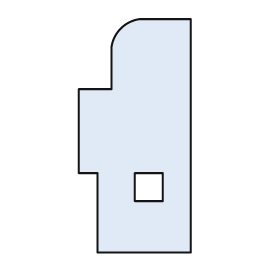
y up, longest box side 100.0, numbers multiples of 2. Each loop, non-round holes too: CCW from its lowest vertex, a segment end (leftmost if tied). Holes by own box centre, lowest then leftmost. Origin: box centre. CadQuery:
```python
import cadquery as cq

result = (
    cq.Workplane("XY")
    .moveTo(-16.0, -50.0)
    .lineTo(24.0, -50.0)
    .lineTo(24.0, 50.0)
    .lineTo(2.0, 50.0)
    .threePointArc((-6.0, 46.0), (-10.0, 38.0))
    .lineTo(-10.0, 20.0)
    .lineTo(-24.0, 20.0)
    .lineTo(-24.0, -16.0)
    .lineTo(-16.0, -16.0)
    .close()
    .moveTo(0.0, -28.0)
    .lineTo(12.0, -28.0)
    .lineTo(12.0, -16.0)
    .lineTo(0.0, -16.0)
    .close()
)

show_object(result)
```